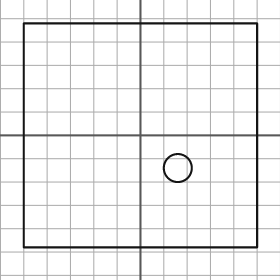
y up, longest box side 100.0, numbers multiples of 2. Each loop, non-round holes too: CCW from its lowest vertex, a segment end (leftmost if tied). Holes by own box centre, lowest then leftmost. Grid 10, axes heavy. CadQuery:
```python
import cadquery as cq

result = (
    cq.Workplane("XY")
    .moveTo(-50.0, -48.0)
    .lineTo(50.0, -48.0)
    .lineTo(50.0, 48.0)
    .lineTo(-50.0, 48.0)
    .close()
    .moveTo(16.0, -14.0)
    .circle(6.0)
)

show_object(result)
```